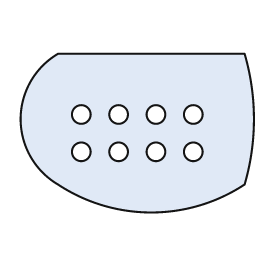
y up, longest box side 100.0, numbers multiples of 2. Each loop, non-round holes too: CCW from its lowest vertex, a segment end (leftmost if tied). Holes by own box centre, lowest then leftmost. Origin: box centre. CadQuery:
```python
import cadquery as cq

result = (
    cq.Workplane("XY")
    .moveTo(-34.0, -22.0)
    .threePointArc((6.0, -34.0), (46.0, -22.0))
    .threePointArc((50.0, 6.0), (46.0, 34.0))
    .lineTo(-34.0, 34.0)
    .threePointArc((-50.0, 6.0), (-34.0, -22.0))
    .close()
    .moveTo(-24.0, -8.0)
    .circle(4.0)
    .moveTo(-8.0, -8.0)
    .circle(4.0)
    .moveTo(8.0, -8.0)
    .circle(4.0)
    .moveTo(24.0, -8.0)
    .circle(4.0)
    .moveTo(-24.0, 8.0)
    .circle(4.0)
    .moveTo(-8.0, 8.0)
    .circle(4.0)
    .moveTo(8.0, 8.0)
    .circle(4.0)
    .moveTo(24.0, 8.0)
    .circle(4.0)
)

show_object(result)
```